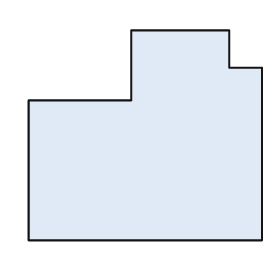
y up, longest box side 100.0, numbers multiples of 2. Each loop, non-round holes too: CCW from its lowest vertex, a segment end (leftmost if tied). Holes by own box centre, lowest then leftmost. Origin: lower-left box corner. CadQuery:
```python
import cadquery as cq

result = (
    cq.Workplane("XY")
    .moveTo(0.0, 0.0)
    .lineTo(100.0, 0.0)
    .lineTo(100.0, 74.0)
    .lineTo(86.0, 74.0)
    .lineTo(86.0, 90.0)
    .lineTo(44.0, 90.0)
    .lineTo(44.0, 60.0)
    .lineTo(0.0, 60.0)
    .close()
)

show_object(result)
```